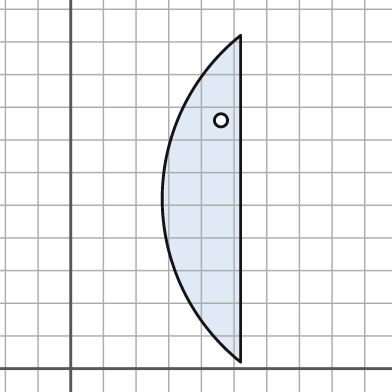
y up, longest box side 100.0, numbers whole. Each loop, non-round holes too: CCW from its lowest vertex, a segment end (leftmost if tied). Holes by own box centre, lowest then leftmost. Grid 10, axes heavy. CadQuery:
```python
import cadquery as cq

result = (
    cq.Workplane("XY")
    .moveTo(52.0, 2.0)
    .lineTo(52.0, 102.0)
    .threePointArc((28.0, 52.0), (52.0, 2.0))
    .close()
    .moveTo(46.0, 76.0)
    .circle(2.0)
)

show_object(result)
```